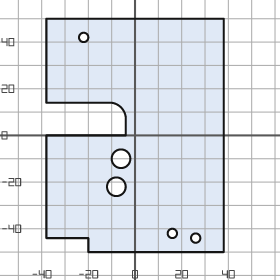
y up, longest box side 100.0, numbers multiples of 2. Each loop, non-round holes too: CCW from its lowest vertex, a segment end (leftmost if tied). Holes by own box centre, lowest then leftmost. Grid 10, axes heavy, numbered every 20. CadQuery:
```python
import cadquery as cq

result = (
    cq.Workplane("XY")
    .moveTo(-20.0, -50.0)
    .lineTo(38.0, -50.0)
    .lineTo(38.0, 50.0)
    .lineTo(-38.0, 50.0)
    .lineTo(-38.0, 14.0)
    .lineTo(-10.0, 14.0)
    .threePointArc((-6.0, 12.0), (-4.0, 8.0))
    .lineTo(-4.0, 0.0)
    .lineTo(-38.0, 0.0)
    .lineTo(-38.0, -44.0)
    .lineTo(-20.0, -44.0)
    .close()
    .moveTo(26.0, -44.0)
    .circle(2.0)
    .moveTo(16.0, -42.0)
    .circle(2.0)
    .moveTo(-8.0, -22.0)
    .circle(4.0)
    .moveTo(-6.0, -10.0)
    .circle(4.0)
    .moveTo(-22.0, 42.0)
    .circle(2.0)
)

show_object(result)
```